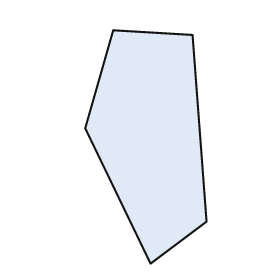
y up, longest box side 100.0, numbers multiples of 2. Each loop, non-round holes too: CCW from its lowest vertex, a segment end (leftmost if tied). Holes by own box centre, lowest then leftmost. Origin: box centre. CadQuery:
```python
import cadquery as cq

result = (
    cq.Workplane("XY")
    .moveTo(2.0, -50.0)
    .lineTo(26.0, -32.0)
    .lineTo(20.0, 48.0)
    .lineTo(-14.0, 50.0)
    .lineTo(-26.0, 8.0)
    .close()
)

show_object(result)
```